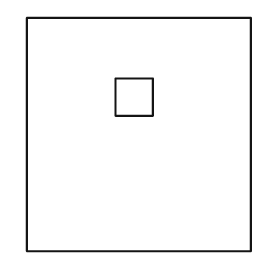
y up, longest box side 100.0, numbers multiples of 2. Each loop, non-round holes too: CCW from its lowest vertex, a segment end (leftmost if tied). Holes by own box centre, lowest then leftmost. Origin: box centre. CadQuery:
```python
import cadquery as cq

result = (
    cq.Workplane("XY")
    .moveTo(-48.0, -50.0)
    .lineTo(48.0, -50.0)
    .lineTo(48.0, 50.0)
    .lineTo(-48.0, 50.0)
    .close()
    .moveTo(-10.0, 8.0)
    .lineTo(6.0, 8.0)
    .lineTo(6.0, 24.0)
    .lineTo(-10.0, 24.0)
    .close()
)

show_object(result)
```